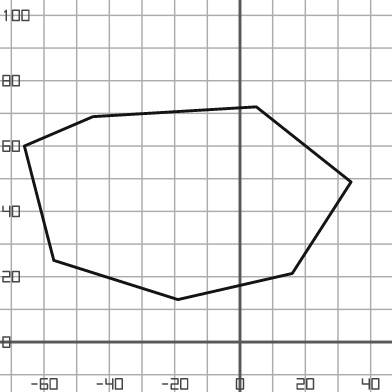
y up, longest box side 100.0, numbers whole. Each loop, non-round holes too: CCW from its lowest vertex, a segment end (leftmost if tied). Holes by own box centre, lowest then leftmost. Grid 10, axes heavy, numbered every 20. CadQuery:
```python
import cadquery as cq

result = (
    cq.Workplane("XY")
    .moveTo(-19.0, 13.0)
    .lineTo(16.0, 21.0)
    .lineTo(34.0, 49.0)
    .lineTo(5.0, 72.0)
    .lineTo(-45.0, 69.0)
    .lineTo(-66.0, 60.0)
    .lineTo(-57.0, 25.0)
    .close()
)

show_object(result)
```